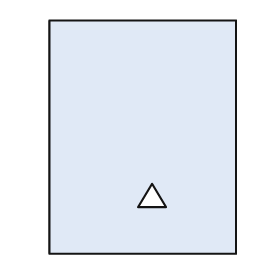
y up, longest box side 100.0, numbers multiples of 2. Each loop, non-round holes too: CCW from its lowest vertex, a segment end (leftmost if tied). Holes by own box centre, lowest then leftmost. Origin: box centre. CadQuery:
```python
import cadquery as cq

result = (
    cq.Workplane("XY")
    .moveTo(-40.0, -50.0)
    .lineTo(40.0, -50.0)
    .lineTo(40.0, 50.0)
    .lineTo(-40.0, 50.0)
    .close()
    .moveTo(-2.0, -30.0)
    .lineTo(10.0, -30.0)
    .lineTo(4.0, -20.0)
    .close()
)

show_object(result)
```